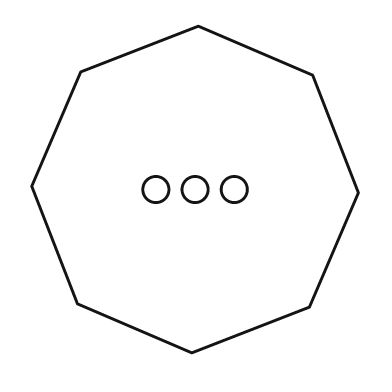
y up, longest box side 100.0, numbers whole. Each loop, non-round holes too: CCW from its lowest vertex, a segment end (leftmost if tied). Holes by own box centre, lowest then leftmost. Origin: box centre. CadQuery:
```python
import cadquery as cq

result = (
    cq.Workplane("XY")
    .moveTo(-1.0, -50.0)
    .lineTo(35.0, -36.0)
    .lineTo(50.0, -1.0)
    .lineTo(36.0, 35.0)
    .lineTo(1.0, 50.0)
    .lineTo(-35.0, 36.0)
    .lineTo(-50.0, 1.0)
    .lineTo(-36.0, -35.0)
    .close()
    .moveTo(-12.0, 0.0)
    .circle(4.0)
    .moveTo(0.0, 0.0)
    .circle(4.0)
    .moveTo(12.0, 0.0)
    .circle(4.0)
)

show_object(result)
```